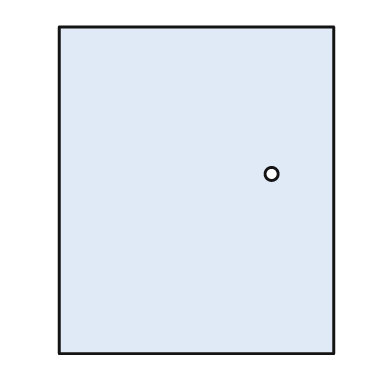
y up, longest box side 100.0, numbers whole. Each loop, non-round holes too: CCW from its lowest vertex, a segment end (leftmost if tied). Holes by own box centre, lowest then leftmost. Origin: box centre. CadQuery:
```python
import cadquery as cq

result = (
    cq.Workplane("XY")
    .moveTo(-42.0, -50.0)
    .lineTo(42.0, -50.0)
    .lineTo(42.0, 50.0)
    .lineTo(-42.0, 50.0)
    .close()
    .moveTo(23.0, 5.0)
    .circle(2.0)
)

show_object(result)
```